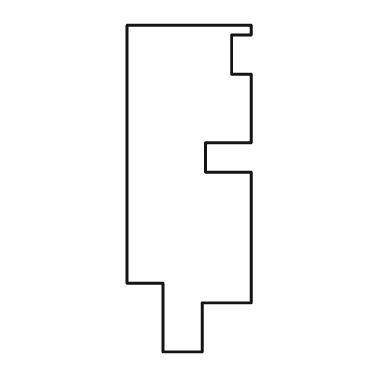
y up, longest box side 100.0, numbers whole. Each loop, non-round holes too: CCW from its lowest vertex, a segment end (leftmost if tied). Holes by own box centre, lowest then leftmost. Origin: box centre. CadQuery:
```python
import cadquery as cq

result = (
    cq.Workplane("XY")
    .moveTo(-8.0, -50.0)
    .lineTo(4.0, -50.0)
    .lineTo(4.0, -35.0)
    .lineTo(19.0, -35.0)
    .lineTo(19.0, 5.0)
    .lineTo(5.0, 5.0)
    .lineTo(5.0, 14.0)
    .lineTo(19.0, 14.0)
    .lineTo(19.0, 35.0)
    .lineTo(13.0, 35.0)
    .lineTo(13.0, 47.0)
    .lineTo(19.0, 47.0)
    .lineTo(19.0, 50.0)
    .lineTo(-19.0, 50.0)
    .lineTo(-19.0, -29.0)
    .lineTo(-8.0, -29.0)
    .close()
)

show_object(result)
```